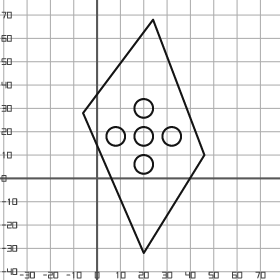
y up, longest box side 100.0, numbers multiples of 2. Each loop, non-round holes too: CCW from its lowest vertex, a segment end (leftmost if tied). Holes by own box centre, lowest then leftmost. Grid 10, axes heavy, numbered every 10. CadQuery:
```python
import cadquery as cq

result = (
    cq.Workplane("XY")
    .moveTo(20.0, -32.0)
    .lineTo(46.0, 10.0)
    .lineTo(24.0, 68.0)
    .lineTo(-6.0, 28.0)
    .close()
    .moveTo(20.0, 6.0)
    .circle(4.0)
    .moveTo(8.0, 18.0)
    .circle(4.0)
    .moveTo(20.0, 18.0)
    .circle(4.0)
    .moveTo(32.0, 18.0)
    .circle(4.0)
    .moveTo(20.0, 30.0)
    .circle(4.0)
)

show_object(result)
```